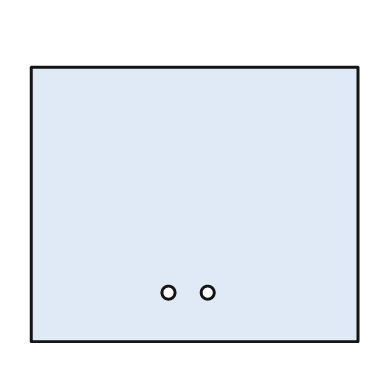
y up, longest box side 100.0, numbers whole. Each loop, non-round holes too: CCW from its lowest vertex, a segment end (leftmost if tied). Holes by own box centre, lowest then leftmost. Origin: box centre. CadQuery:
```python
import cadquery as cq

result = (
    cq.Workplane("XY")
    .moveTo(-50.0, -42.0)
    .lineTo(50.0, -42.0)
    .lineTo(50.0, 42.0)
    .lineTo(-50.0, 42.0)
    .close()
    .moveTo(-8.0, -27.0)
    .circle(2.0)
    .moveTo(4.0, -27.0)
    .circle(2.0)
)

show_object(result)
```